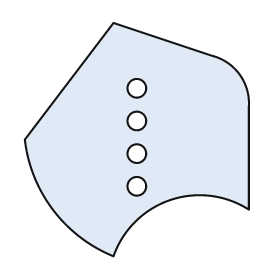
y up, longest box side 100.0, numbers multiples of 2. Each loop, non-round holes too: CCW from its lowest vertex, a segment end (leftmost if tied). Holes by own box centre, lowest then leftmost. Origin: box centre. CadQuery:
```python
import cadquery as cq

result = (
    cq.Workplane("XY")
    .moveTo(-10.0, -50.0)
    .threePointArc((14.0, -26.0), (48.0, -30.0))
    .lineTo(48.0, 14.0)
    .threePointArc((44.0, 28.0), (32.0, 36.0))
    .lineTo(-10.0, 50.0)
    .lineTo(-48.0, 0.0)
    .threePointArc((-36.0, -30.0), (-10.0, -50.0))
    .close()
    .moveTo(0.0, -20.0)
    .circle(4.0)
    .moveTo(0.0, -6.0)
    .circle(4.0)
    .moveTo(0.0, 8.0)
    .circle(4.0)
    .moveTo(0.0, 22.0)
    .circle(4.0)
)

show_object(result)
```